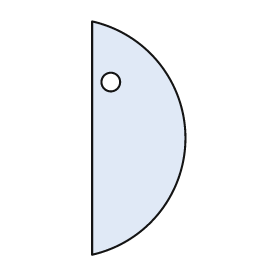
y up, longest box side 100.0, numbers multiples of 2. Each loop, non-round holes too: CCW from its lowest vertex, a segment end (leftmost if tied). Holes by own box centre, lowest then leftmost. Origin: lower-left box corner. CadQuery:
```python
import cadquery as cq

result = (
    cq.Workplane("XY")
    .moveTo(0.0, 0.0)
    .threePointArc((40.0, 50.0), (0.0, 100.0))
    .close()
    .moveTo(8.0, 74.0)
    .circle(4.0)
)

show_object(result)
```